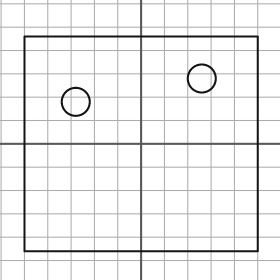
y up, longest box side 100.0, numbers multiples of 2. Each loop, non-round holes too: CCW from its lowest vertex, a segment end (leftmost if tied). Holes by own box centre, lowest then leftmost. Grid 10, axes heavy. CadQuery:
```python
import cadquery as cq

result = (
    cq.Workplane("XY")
    .moveTo(-50.0, -46.0)
    .lineTo(50.0, -46.0)
    .lineTo(50.0, 46.0)
    .lineTo(-50.0, 46.0)
    .close()
    .moveTo(-28.0, 18.0)
    .circle(6.0)
    .moveTo(26.0, 28.0)
    .circle(6.0)
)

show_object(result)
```